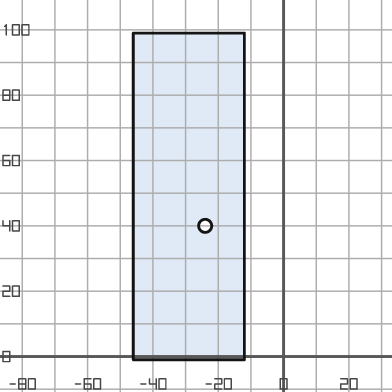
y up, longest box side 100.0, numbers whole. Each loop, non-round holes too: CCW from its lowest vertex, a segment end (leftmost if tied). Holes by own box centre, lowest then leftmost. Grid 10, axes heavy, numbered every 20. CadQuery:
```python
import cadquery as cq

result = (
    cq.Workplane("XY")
    .moveTo(-46.0, -1.0)
    .lineTo(-12.0, -1.0)
    .lineTo(-12.0, 99.0)
    .lineTo(-46.0, 99.0)
    .close()
    .moveTo(-24.0, 40.0)
    .circle(2.0)
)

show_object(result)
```